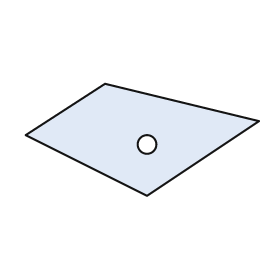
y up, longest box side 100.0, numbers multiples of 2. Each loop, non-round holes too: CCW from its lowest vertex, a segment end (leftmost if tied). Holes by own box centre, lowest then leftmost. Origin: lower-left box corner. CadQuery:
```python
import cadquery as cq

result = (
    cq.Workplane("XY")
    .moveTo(52.0, 0.0)
    .lineTo(100.0, 32.0)
    .lineTo(34.0, 48.0)
    .lineTo(0.0, 26.0)
    .close()
    .moveTo(52.0, 22.0)
    .circle(4.0)
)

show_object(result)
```